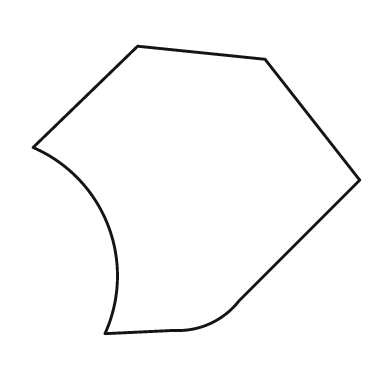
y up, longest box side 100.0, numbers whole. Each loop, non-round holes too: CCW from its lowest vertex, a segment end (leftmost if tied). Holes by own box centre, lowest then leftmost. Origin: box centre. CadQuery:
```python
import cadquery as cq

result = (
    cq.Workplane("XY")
    .moveTo(-28.0, -44.0)
    .lineTo(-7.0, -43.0)
    .threePointArc((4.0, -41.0), (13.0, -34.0))
    .lineTo(50.0, 3.0)
    .lineTo(21.0, 40.0)
    .lineTo(-18.0, 44.0)
    .lineTo(-50.0, 13.0)
    .threePointArc((-27.0, -11.0), (-28.0, -44.0))
    .close()
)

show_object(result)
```